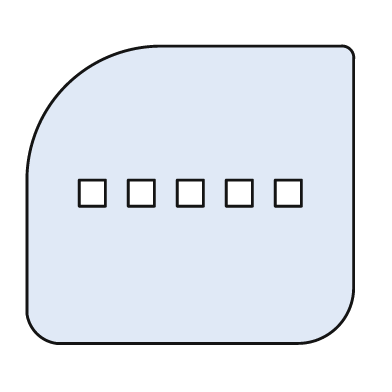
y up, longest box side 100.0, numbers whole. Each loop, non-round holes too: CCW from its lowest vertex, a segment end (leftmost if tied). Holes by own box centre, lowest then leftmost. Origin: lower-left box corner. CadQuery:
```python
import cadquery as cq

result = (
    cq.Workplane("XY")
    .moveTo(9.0, 0.0)
    .lineTo(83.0, 0.0)
    .threePointArc((95.0, 5.0), (100.0, 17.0))
    .lineTo(100.0, 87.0)
    .threePointArc((99.0, 90.0), (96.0, 91.0))
    .lineTo(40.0, 91.0)
    .threePointArc((12.0, 79.0), (0.0, 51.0))
    .lineTo(0.0, 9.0)
    .threePointArc((3.0, 3.0), (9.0, 0.0))
    .close()
    .moveTo(16.0, 42.0)
    .lineTo(24.0, 42.0)
    .lineTo(24.0, 50.0)
    .lineTo(16.0, 50.0)
    .close()
    .moveTo(31.0, 42.0)
    .lineTo(39.0, 42.0)
    .lineTo(39.0, 50.0)
    .lineTo(31.0, 50.0)
    .close()
    .moveTo(46.0, 42.0)
    .lineTo(54.0, 42.0)
    .lineTo(54.0, 50.0)
    .lineTo(46.0, 50.0)
    .close()
    .moveTo(61.0, 42.0)
    .lineTo(69.0, 42.0)
    .lineTo(69.0, 50.0)
    .lineTo(61.0, 50.0)
    .close()
    .moveTo(76.0, 42.0)
    .lineTo(84.0, 42.0)
    .lineTo(84.0, 50.0)
    .lineTo(76.0, 50.0)
    .close()
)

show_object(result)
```